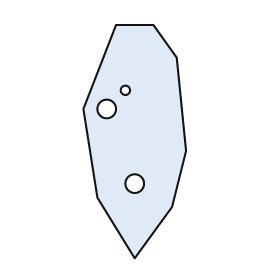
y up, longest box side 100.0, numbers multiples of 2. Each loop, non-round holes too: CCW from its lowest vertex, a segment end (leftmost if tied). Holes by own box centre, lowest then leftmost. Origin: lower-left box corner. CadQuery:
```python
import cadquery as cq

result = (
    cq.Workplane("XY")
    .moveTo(22.0, 0.0)
    .lineTo(38.0, 22.0)
    .lineTo(44.0, 46.0)
    .lineTo(40.0, 86.0)
    .lineTo(30.0, 100.0)
    .lineTo(14.0, 100.0)
    .lineTo(0.0, 64.0)
    .lineTo(6.0, 26.0)
    .close()
    .moveTo(22.0, 32.0)
    .circle(4.0)
    .moveTo(10.0, 64.0)
    .circle(4.0)
    .moveTo(18.0, 72.0)
    .circle(2.0)
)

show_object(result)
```